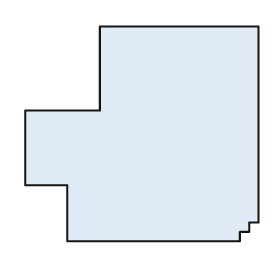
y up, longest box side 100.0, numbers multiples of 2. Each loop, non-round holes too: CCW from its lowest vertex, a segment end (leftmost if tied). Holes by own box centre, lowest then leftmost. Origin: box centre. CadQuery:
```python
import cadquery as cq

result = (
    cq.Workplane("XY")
    .moveTo(-32.0, -46.0)
    .lineTo(42.0, -46.0)
    .lineTo(42.0, -42.0)
    .lineTo(46.0, -42.0)
    .lineTo(46.0, -38.0)
    .lineTo(50.0, -38.0)
    .lineTo(50.0, 46.0)
    .lineTo(-18.0, 46.0)
    .lineTo(-18.0, 10.0)
    .lineTo(-50.0, 10.0)
    .lineTo(-50.0, -22.0)
    .lineTo(-32.0, -22.0)
    .close()
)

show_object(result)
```